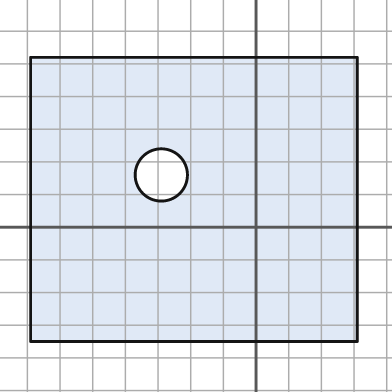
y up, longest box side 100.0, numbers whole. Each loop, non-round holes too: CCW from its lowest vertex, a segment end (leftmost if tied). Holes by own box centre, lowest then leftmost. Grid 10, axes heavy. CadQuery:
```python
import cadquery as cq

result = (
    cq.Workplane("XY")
    .moveTo(-69.0, -35.0)
    .lineTo(31.0, -35.0)
    .lineTo(31.0, 52.0)
    .lineTo(-69.0, 52.0)
    .close()
    .moveTo(-29.0, 16.0)
    .circle(8.0)
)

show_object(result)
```